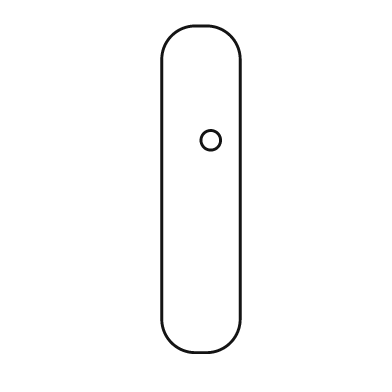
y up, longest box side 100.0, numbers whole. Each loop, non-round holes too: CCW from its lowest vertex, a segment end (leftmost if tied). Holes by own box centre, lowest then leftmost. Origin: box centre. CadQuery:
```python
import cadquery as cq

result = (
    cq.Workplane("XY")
    .moveTo(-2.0, -50.0)
    .lineTo(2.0, -50.0)
    .threePointArc((9.0, -47.0), (12.0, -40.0))
    .lineTo(12.0, 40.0)
    .threePointArc((9.0, 47.0), (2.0, 50.0))
    .lineTo(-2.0, 50.0)
    .threePointArc((-9.0, 47.0), (-12.0, 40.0))
    .lineTo(-12.0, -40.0)
    .threePointArc((-9.0, -47.0), (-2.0, -50.0))
    .close()
    .moveTo(3.0, 15.0)
    .circle(3.0)
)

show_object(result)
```